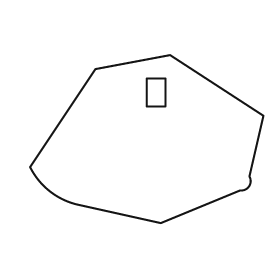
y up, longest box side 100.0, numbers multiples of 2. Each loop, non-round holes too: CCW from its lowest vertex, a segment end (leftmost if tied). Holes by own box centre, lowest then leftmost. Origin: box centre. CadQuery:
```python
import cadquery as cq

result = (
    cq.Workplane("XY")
    .moveTo(6.0, -36.0)
    .lineTo(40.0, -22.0)
    .threePointArc((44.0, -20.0), (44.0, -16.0))
    .lineTo(50.0, 10.0)
    .lineTo(10.0, 36.0)
    .lineTo(-22.0, 30.0)
    .lineTo(-50.0, -12.0)
    .threePointArc((-42.0, -22.0), (-30.0, -28.0))
    .close()
    .moveTo(0.0, 14.0)
    .lineTo(8.0, 14.0)
    .lineTo(8.0, 26.0)
    .lineTo(0.0, 26.0)
    .close()
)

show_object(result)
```